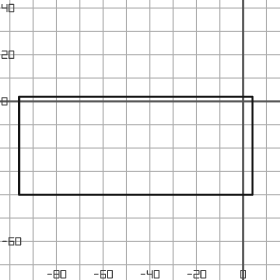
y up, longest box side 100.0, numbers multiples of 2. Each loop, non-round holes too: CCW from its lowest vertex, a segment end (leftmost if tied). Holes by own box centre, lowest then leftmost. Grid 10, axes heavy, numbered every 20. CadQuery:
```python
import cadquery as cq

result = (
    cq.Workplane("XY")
    .moveTo(-96.0, -40.0)
    .lineTo(4.0, -40.0)
    .lineTo(4.0, 2.0)
    .lineTo(-96.0, 2.0)
    .close()
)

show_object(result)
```